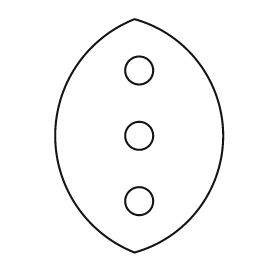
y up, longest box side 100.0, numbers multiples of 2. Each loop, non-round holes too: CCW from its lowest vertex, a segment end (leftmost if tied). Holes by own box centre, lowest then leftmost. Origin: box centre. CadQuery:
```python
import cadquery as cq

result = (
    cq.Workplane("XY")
    .moveTo(-2.0, -50.0)
    .threePointArc((36.0, 0.0), (-2.0, 50.0))
    .threePointArc((-36.0, 0.0), (-2.0, -50.0))
    .close()
    .moveTo(0.0, -28.0)
    .circle(6.0)
    .moveTo(0.0, 0.0)
    .circle(6.0)
    .moveTo(0.0, 28.0)
    .circle(6.0)
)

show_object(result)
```